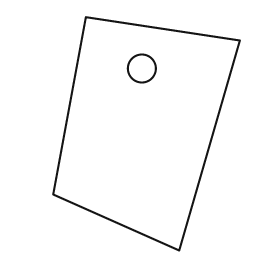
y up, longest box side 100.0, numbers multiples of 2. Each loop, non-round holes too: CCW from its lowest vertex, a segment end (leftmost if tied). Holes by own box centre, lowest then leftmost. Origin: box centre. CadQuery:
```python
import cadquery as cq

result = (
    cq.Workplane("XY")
    .moveTo(14.0, -50.0)
    .lineTo(40.0, 40.0)
    .lineTo(-26.0, 50.0)
    .lineTo(-40.0, -26.0)
    .close()
    .moveTo(-2.0, 28.0)
    .circle(6.0)
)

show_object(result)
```